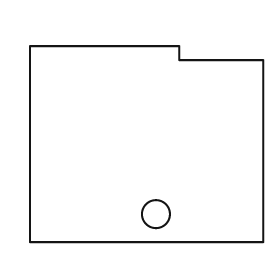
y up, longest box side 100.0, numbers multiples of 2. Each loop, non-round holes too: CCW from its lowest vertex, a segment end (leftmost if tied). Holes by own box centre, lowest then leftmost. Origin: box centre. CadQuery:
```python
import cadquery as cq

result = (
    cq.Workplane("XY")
    .moveTo(-50.0, -42.0)
    .lineTo(50.0, -42.0)
    .lineTo(50.0, 36.0)
    .lineTo(14.0, 36.0)
    .lineTo(14.0, 42.0)
    .lineTo(-50.0, 42.0)
    .close()
    .moveTo(4.0, -30.0)
    .circle(6.0)
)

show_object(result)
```